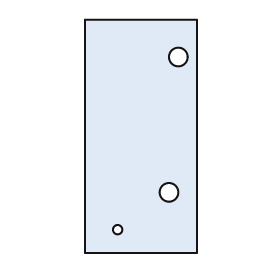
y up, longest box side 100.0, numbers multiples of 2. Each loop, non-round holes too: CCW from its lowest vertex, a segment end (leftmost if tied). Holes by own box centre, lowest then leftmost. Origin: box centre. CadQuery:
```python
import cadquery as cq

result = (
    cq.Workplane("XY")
    .moveTo(-24.0, -50.0)
    .lineTo(24.0, -50.0)
    .lineTo(24.0, 50.0)
    .lineTo(-24.0, 50.0)
    .close()
    .moveTo(-10.0, -40.0)
    .circle(2.0)
    .moveTo(12.0, -24.0)
    .circle(4.0)
    .moveTo(16.0, 34.0)
    .circle(4.0)
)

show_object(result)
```